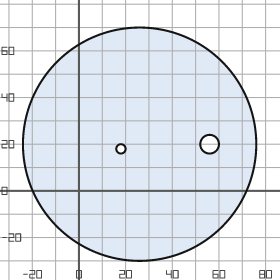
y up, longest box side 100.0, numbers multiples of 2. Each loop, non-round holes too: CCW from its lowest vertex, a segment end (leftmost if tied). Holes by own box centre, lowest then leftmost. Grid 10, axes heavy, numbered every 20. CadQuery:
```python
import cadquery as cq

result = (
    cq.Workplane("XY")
    .moveTo(26.0, 20.0)
    .circle(50.0)
    .moveTo(18.0, 18.0)
    .circle(2.0)
    .moveTo(56.0, 20.0)
    .circle(4.0)
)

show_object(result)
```